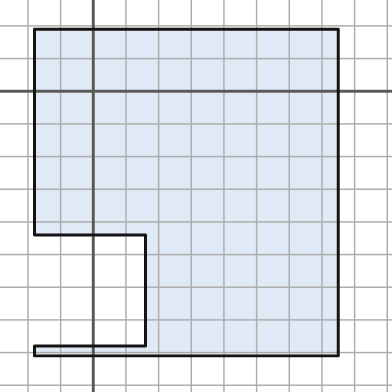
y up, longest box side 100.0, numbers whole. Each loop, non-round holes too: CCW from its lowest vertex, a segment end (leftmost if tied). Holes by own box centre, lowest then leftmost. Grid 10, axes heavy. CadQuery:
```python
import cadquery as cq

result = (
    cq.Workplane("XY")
    .moveTo(-18.0, -81.0)
    .lineTo(75.0, -81.0)
    .lineTo(75.0, 19.0)
    .lineTo(-18.0, 19.0)
    .lineTo(-18.0, -44.0)
    .lineTo(16.0, -44.0)
    .lineTo(16.0, -78.0)
    .lineTo(-18.0, -78.0)
    .close()
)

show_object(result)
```